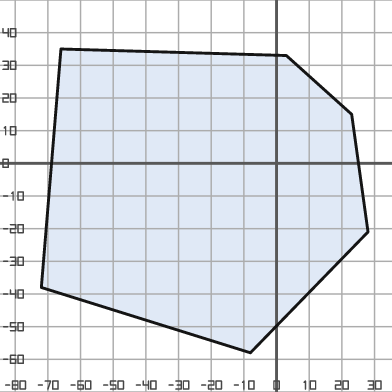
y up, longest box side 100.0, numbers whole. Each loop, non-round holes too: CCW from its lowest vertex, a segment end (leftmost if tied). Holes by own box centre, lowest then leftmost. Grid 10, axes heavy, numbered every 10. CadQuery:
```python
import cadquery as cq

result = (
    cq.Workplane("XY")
    .moveTo(-8.0, -58.0)
    .lineTo(28.0, -21.0)
    .lineTo(23.0, 15.0)
    .lineTo(3.0, 33.0)
    .lineTo(-66.0, 35.0)
    .lineTo(-72.0, -38.0)
    .close()
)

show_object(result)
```